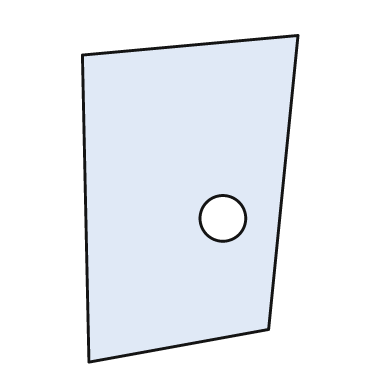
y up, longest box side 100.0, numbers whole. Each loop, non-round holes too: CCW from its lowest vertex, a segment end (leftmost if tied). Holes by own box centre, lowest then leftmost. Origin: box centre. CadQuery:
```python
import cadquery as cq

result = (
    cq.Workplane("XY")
    .moveTo(-31.0, -50.0)
    .lineTo(24.0, -40.0)
    .lineTo(33.0, 50.0)
    .lineTo(-33.0, 44.0)
    .close()
    .moveTo(10.0, -6.0)
    .circle(7.0)
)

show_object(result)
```